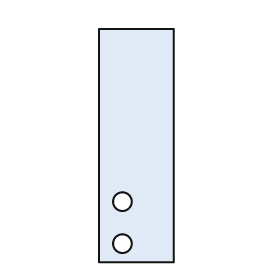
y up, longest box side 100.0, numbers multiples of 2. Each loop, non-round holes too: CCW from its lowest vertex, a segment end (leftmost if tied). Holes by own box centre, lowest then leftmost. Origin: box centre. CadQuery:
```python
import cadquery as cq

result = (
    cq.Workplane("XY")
    .moveTo(-16.0, -50.0)
    .lineTo(16.0, -50.0)
    .lineTo(16.0, 50.0)
    .lineTo(-16.0, 50.0)
    .close()
    .moveTo(-6.0, -42.0)
    .circle(4.0)
    .moveTo(-6.0, -24.0)
    .circle(4.0)
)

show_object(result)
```